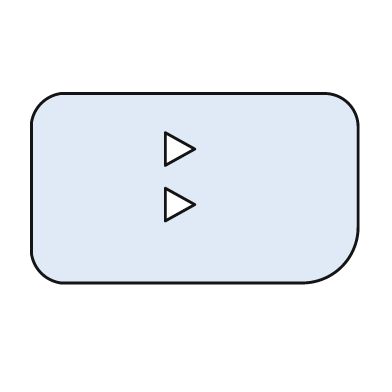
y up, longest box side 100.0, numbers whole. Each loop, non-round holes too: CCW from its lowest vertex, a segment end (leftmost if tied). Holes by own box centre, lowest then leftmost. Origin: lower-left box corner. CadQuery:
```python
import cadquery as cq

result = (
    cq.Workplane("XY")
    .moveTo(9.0, 0.0)
    .lineTo(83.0, 0.0)
    .threePointArc((95.0, 5.0), (100.0, 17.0))
    .lineTo(100.0, 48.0)
    .threePointArc((97.0, 55.0), (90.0, 58.0))
    .lineTo(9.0, 58.0)
    .threePointArc((3.0, 55.0), (0.0, 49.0))
    .lineTo(0.0, 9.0)
    .threePointArc((3.0, 3.0), (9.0, 0.0))
    .close()
    .moveTo(41.0, 19.0)
    .lineTo(50.0, 24.0)
    .lineTo(41.0, 29.0)
    .close()
    .moveTo(41.0, 36.0)
    .lineTo(50.0, 41.0)
    .lineTo(41.0, 46.0)
    .close()
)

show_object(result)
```